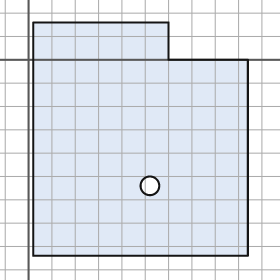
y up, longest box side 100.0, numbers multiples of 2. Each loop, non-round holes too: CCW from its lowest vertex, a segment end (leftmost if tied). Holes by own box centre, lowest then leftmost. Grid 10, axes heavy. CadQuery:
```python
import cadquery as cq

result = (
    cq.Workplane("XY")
    .moveTo(2.0, -84.0)
    .lineTo(94.0, -84.0)
    .lineTo(94.0, 0.0)
    .lineTo(60.0, 0.0)
    .lineTo(60.0, 16.0)
    .lineTo(2.0, 16.0)
    .close()
    .moveTo(52.0, -54.0)
    .circle(4.0)
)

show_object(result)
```